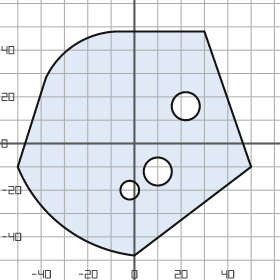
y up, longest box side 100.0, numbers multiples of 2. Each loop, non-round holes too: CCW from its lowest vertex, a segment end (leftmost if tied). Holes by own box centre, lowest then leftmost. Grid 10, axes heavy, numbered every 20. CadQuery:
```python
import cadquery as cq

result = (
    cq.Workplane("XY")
    .moveTo(0.0, -48.0)
    .lineTo(50.0, -10.0)
    .lineTo(30.0, 48.0)
    .lineTo(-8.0, 48.0)
    .threePointArc((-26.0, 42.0), (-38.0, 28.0))
    .lineTo(-50.0, -10.0)
    .threePointArc((-30.0, -36.0), (0.0, -48.0))
    .close()
    .moveTo(-2.0, -20.0)
    .circle(4.0)
    .moveTo(10.0, -12.0)
    .circle(6.0)
    .moveTo(22.0, 16.0)
    .circle(6.0)
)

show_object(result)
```